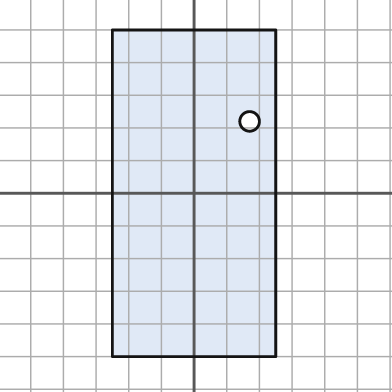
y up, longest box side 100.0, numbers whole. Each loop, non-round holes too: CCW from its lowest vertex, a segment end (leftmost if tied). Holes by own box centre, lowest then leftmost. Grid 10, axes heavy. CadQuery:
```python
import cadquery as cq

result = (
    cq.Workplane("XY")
    .moveTo(-25.0, -50.0)
    .lineTo(25.0, -50.0)
    .lineTo(25.0, 50.0)
    .lineTo(-25.0, 50.0)
    .close()
    .moveTo(17.0, 22.0)
    .circle(3.0)
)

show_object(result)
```